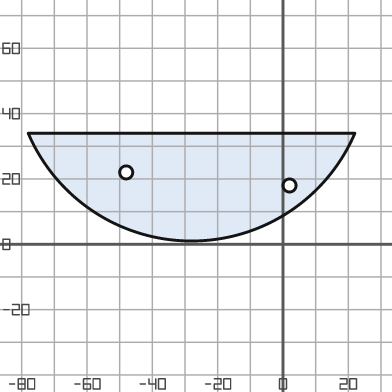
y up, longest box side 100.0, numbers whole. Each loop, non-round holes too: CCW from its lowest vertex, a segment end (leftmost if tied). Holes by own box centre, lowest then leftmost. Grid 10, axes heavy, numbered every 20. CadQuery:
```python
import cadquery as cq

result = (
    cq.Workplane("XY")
    .moveTo(-78.0, 34.0)
    .threePointArc((-28.0, 1.0), (22.0, 34.0))
    .close()
    .moveTo(2.0, 18.0)
    .circle(2.0)
    .moveTo(-48.0, 22.0)
    .circle(2.0)
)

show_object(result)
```